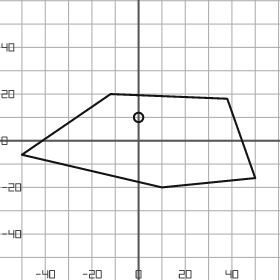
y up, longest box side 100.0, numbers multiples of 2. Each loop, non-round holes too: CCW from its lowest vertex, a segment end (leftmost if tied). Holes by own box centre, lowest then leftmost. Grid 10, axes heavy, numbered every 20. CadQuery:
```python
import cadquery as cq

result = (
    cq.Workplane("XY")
    .moveTo(10.0, -20.0)
    .lineTo(50.0, -16.0)
    .lineTo(38.0, 18.0)
    .lineTo(-12.0, 20.0)
    .lineTo(-50.0, -6.0)
    .close()
    .moveTo(0.0, 10.0)
    .circle(2.0)
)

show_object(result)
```